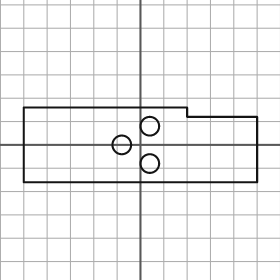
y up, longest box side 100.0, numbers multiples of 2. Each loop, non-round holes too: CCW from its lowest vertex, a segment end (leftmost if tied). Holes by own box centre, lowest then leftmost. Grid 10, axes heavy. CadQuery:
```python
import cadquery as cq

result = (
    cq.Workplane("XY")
    .moveTo(-50.0, -16.0)
    .lineTo(50.0, -16.0)
    .lineTo(50.0, 12.0)
    .lineTo(20.0, 12.0)
    .lineTo(20.0, 16.0)
    .lineTo(-50.0, 16.0)
    .close()
    .moveTo(4.0, -8.0)
    .circle(4.0)
    .moveTo(-8.0, 0.0)
    .circle(4.0)
    .moveTo(4.0, 8.0)
    .circle(4.0)
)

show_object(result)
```